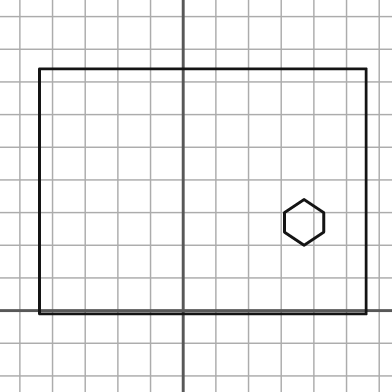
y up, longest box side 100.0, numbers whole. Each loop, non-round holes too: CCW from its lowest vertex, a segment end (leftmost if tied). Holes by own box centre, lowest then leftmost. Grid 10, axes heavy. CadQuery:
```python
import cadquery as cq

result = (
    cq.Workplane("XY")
    .moveTo(-44.0, -1.0)
    .lineTo(56.0, -1.0)
    .lineTo(56.0, 74.0)
    .lineTo(-44.0, 74.0)
    .close()
    .moveTo(37.0, 20.0)
    .lineTo(43.0, 24.0)
    .lineTo(43.0, 30.0)
    .lineTo(37.0, 34.0)
    .lineTo(31.0, 30.0)
    .lineTo(31.0, 24.0)
    .close()
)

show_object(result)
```